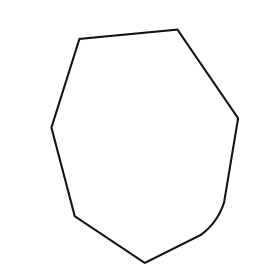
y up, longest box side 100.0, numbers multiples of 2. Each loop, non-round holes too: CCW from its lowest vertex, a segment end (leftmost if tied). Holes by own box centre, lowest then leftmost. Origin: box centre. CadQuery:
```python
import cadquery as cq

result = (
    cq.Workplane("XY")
    .moveTo(0.0, -50.0)
    .lineTo(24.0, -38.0)
    .threePointArc((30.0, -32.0), (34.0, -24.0))
    .lineTo(40.0, 12.0)
    .lineTo(14.0, 50.0)
    .lineTo(-28.0, 46.0)
    .lineTo(-40.0, 8.0)
    .lineTo(-30.0, -30.0)
    .close()
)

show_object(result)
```